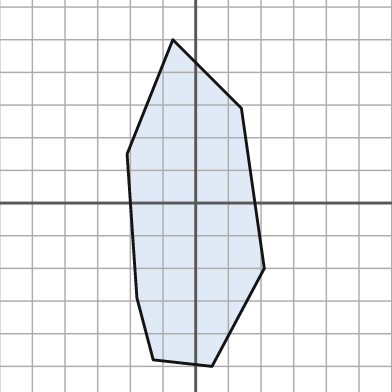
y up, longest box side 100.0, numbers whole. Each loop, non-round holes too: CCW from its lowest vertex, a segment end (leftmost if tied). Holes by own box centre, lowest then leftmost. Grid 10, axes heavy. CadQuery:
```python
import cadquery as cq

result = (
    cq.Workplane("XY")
    .moveTo(5.0, -50.0)
    .lineTo(21.0, -20.0)
    .lineTo(14.0, 29.0)
    .lineTo(-7.0, 50.0)
    .lineTo(-21.0, 15.0)
    .lineTo(-18.0, -29.0)
    .lineTo(-13.0, -48.0)
    .close()
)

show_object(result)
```